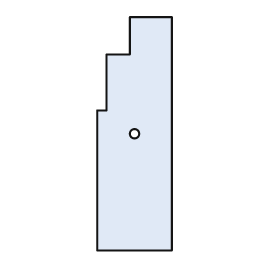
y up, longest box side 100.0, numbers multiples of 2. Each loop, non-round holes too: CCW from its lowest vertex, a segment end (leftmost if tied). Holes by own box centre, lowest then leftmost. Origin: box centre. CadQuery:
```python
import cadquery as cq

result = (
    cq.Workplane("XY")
    .moveTo(-16.0, -50.0)
    .lineTo(16.0, -50.0)
    .lineTo(16.0, 50.0)
    .lineTo(-2.0, 50.0)
    .lineTo(-2.0, 34.0)
    .lineTo(-12.0, 34.0)
    .lineTo(-12.0, 10.0)
    .lineTo(-16.0, 10.0)
    .close()
    .moveTo(0.0, 0.0)
    .circle(2.0)
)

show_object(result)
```